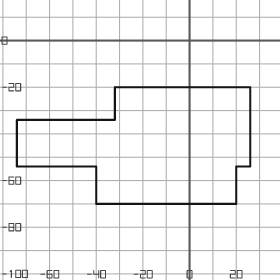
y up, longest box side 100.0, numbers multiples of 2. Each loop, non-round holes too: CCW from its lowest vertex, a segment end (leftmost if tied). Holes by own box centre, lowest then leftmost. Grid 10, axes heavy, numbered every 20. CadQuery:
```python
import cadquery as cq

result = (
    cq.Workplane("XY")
    .moveTo(-40.0, -70.0)
    .lineTo(20.0, -70.0)
    .lineTo(20.0, -54.0)
    .lineTo(26.0, -54.0)
    .lineTo(26.0, -20.0)
    .lineTo(-32.0, -20.0)
    .lineTo(-32.0, -34.0)
    .lineTo(-74.0, -34.0)
    .lineTo(-74.0, -54.0)
    .lineTo(-40.0, -54.0)
    .close()
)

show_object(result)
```